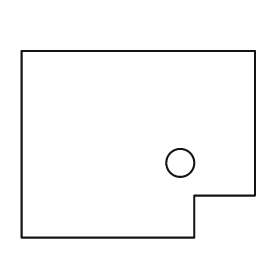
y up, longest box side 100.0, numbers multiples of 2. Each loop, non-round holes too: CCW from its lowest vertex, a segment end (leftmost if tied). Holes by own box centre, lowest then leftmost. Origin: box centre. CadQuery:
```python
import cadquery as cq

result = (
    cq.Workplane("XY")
    .moveTo(-50.0, -40.0)
    .lineTo(24.0, -40.0)
    .lineTo(24.0, -22.0)
    .lineTo(50.0, -22.0)
    .lineTo(50.0, 40.0)
    .lineTo(-50.0, 40.0)
    .close()
    .moveTo(18.0, -8.0)
    .circle(6.0)
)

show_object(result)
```